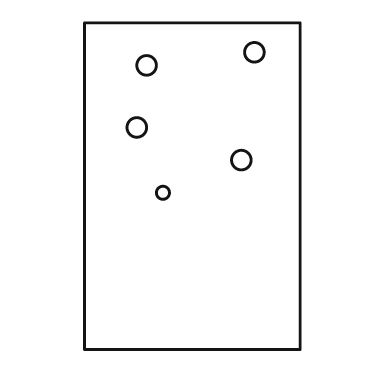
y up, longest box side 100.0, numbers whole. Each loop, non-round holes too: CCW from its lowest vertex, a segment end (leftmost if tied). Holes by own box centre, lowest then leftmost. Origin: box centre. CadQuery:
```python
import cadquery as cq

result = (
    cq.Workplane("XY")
    .moveTo(-33.0, -50.0)
    .lineTo(33.0, -50.0)
    .lineTo(33.0, 50.0)
    .lineTo(-33.0, 50.0)
    .close()
    .moveTo(-9.0, -2.0)
    .circle(2.0)
    .moveTo(15.0, 8.0)
    .circle(3.0)
    .moveTo(-17.0, 18.0)
    .circle(3.0)
    .moveTo(-14.0, 37.0)
    .circle(3.0)
    .moveTo(19.0, 41.0)
    .circle(3.0)
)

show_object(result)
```